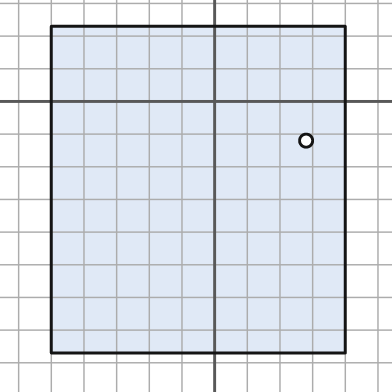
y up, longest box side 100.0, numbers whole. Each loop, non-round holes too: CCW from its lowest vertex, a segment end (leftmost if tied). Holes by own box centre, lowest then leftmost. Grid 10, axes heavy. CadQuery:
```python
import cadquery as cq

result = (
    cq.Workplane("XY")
    .moveTo(-50.0, -77.0)
    .lineTo(40.0, -77.0)
    .lineTo(40.0, 23.0)
    .lineTo(-50.0, 23.0)
    .close()
    .moveTo(28.0, -12.0)
    .circle(2.0)
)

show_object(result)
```